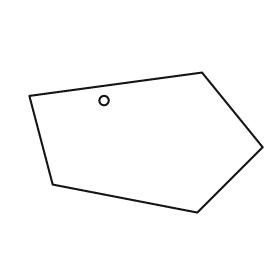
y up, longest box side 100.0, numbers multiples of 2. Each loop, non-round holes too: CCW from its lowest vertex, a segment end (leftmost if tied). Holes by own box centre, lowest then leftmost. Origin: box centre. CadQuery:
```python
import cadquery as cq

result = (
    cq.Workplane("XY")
    .moveTo(22.0, -30.0)
    .lineTo(50.0, -2.0)
    .lineTo(24.0, 30.0)
    .lineTo(-50.0, 20.0)
    .lineTo(-40.0, -18.0)
    .close()
    .moveTo(-18.0, 18.0)
    .circle(2.0)
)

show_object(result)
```